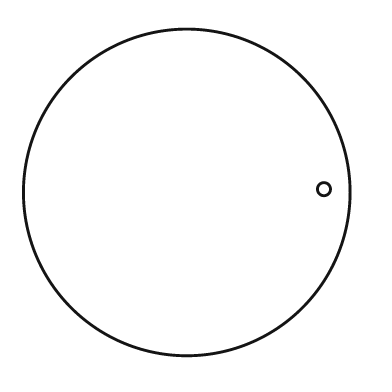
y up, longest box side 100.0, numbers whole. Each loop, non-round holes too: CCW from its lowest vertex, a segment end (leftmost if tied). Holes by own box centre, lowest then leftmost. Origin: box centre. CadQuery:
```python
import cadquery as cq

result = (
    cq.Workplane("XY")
    .moveTo(0.0, 0.0)
    .circle(50.0)
    .moveTo(42.0, 1.0)
    .circle(2.0)
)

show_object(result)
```